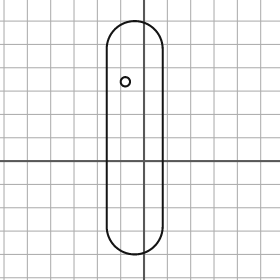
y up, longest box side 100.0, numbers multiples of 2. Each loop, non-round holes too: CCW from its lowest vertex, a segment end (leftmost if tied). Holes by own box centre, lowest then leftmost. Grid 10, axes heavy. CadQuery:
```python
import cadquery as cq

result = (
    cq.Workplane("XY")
    .moveTo(-16.0, -28.0)
    .threePointArc((-4.0, -40.0), (8.0, -28.0))
    .lineTo(8.0, 48.0)
    .threePointArc((-4.0, 60.0), (-16.0, 48.0))
    .close()
    .moveTo(-8.0, 34.0)
    .circle(2.0)
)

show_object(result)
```